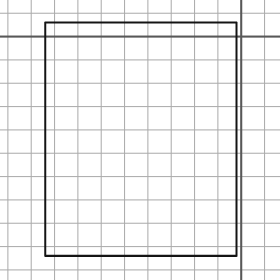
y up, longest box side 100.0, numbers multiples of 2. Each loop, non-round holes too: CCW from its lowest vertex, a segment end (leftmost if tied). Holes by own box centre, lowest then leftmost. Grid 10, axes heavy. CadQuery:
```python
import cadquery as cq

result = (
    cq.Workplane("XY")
    .moveTo(-84.0, -94.0)
    .lineTo(-2.0, -94.0)
    .lineTo(-2.0, 6.0)
    .lineTo(-84.0, 6.0)
    .close()
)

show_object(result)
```